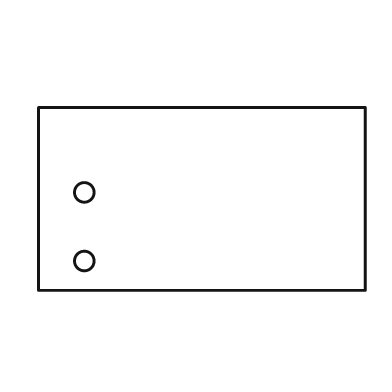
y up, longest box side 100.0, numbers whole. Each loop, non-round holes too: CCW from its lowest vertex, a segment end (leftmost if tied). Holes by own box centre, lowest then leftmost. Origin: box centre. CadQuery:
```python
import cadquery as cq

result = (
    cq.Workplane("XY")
    .moveTo(-50.0, -28.0)
    .lineTo(50.0, -28.0)
    .lineTo(50.0, 28.0)
    .lineTo(-50.0, 28.0)
    .close()
    .moveTo(-36.0, -19.0)
    .circle(3.0)
    .moveTo(-36.0, 2.0)
    .circle(3.0)
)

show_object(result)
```